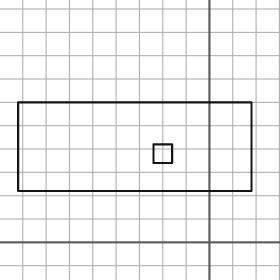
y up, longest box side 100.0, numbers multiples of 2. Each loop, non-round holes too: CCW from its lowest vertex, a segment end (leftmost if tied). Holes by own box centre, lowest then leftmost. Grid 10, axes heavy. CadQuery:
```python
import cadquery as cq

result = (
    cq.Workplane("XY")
    .moveTo(-82.0, 22.0)
    .lineTo(18.0, 22.0)
    .lineTo(18.0, 60.0)
    .lineTo(-82.0, 60.0)
    .close()
    .moveTo(-24.0, 34.0)
    .lineTo(-16.0, 34.0)
    .lineTo(-16.0, 42.0)
    .lineTo(-24.0, 42.0)
    .close()
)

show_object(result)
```